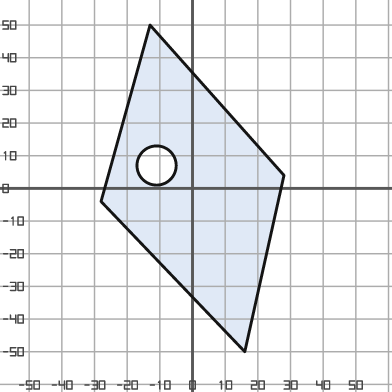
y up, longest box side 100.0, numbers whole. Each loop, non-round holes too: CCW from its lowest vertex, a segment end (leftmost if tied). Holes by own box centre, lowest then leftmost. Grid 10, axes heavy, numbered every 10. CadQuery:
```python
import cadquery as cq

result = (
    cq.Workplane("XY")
    .moveTo(16.0, -50.0)
    .lineTo(28.0, 4.0)
    .lineTo(-13.0, 50.0)
    .lineTo(-28.0, -4.0)
    .close()
    .moveTo(-11.0, 7.0)
    .circle(6.0)
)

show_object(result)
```